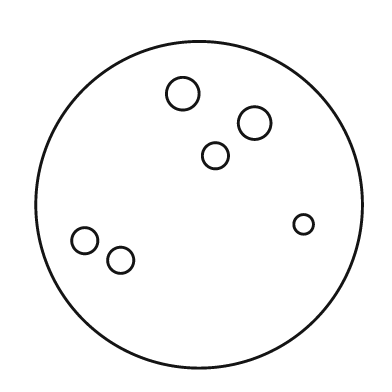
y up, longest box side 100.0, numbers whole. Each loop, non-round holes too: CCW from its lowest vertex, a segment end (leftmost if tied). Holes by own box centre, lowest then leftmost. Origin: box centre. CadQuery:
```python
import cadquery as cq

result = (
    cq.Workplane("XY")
    .moveTo(0.0, 0.0)
    .circle(50.0)
    .moveTo(-24.0, -17.0)
    .circle(4.0)
    .moveTo(-35.0, -11.0)
    .circle(4.0)
    .moveTo(32.0, -6.0)
    .circle(3.0)
    .moveTo(5.0, 15.0)
    .circle(4.0)
    .moveTo(17.0, 25.0)
    .circle(5.0)
    .moveTo(-5.0, 34.0)
    .circle(5.0)
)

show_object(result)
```